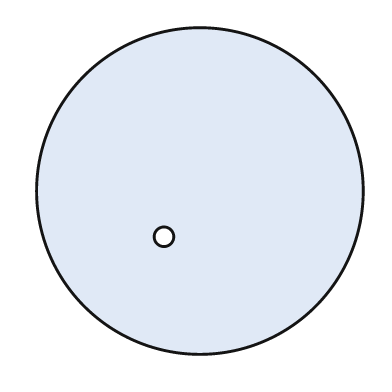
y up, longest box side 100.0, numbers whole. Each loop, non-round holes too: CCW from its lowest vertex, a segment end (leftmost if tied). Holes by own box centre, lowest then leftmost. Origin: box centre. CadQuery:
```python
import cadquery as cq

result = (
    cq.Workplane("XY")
    .moveTo(0.0, 0.0)
    .circle(50.0)
    .moveTo(-11.0, -14.0)
    .circle(3.0)
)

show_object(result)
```